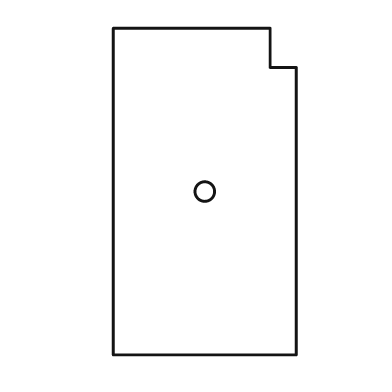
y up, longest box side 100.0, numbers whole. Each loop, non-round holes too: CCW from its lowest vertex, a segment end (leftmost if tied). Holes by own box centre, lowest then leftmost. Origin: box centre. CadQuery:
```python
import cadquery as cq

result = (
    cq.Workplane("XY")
    .moveTo(-28.0, -50.0)
    .lineTo(28.0, -50.0)
    .lineTo(28.0, 38.0)
    .lineTo(20.0, 38.0)
    .lineTo(20.0, 50.0)
    .lineTo(-28.0, 50.0)
    .close()
    .moveTo(0.0, 0.0)
    .circle(3.0)
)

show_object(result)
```